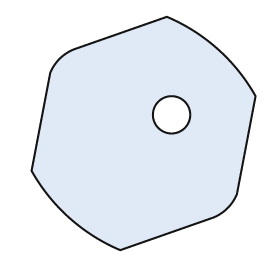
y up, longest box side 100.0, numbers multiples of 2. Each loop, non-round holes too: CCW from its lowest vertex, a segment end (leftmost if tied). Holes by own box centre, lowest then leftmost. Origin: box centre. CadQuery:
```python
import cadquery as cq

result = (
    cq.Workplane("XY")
    .moveTo(-10.0, -50.0)
    .lineTo(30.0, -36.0)
    .threePointArc((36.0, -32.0), (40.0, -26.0))
    .lineTo(48.0, 16.0)
    .threePointArc((32.0, 36.0), (10.0, 50.0))
    .lineTo(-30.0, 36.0)
    .threePointArc((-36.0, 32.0), (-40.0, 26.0))
    .lineTo(-48.0, -16.0)
    .threePointArc((-32.0, -36.0), (-10.0, -50.0))
    .close()
    .moveTo(12.0, 8.0)
    .circle(8.0)
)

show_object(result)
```